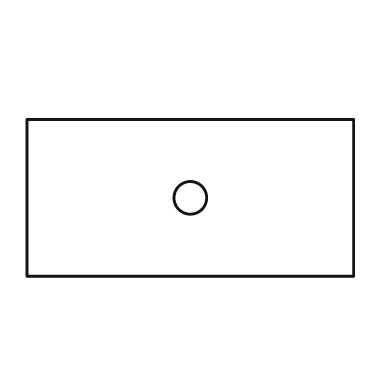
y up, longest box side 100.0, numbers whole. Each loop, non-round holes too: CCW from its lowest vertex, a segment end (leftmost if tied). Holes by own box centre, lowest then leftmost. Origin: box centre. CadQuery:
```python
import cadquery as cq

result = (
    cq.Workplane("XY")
    .moveTo(-50.0, -24.0)
    .lineTo(50.0, -24.0)
    .lineTo(50.0, 24.0)
    .lineTo(-50.0, 24.0)
    .close()
    .moveTo(0.0, 0.0)
    .circle(5.0)
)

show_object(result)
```